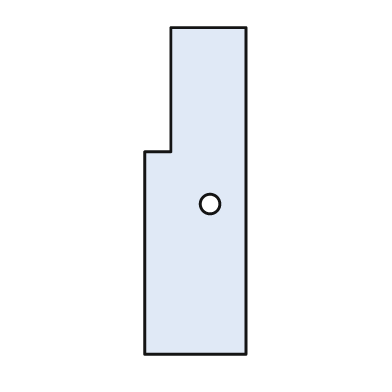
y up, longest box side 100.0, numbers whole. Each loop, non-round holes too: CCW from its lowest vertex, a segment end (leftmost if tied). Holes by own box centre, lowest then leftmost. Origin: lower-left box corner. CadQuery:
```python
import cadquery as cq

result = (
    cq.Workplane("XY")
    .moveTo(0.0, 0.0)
    .lineTo(31.0, 0.0)
    .lineTo(31.0, 100.0)
    .lineTo(8.0, 100.0)
    .lineTo(8.0, 62.0)
    .lineTo(0.0, 62.0)
    .close()
    .moveTo(20.0, 46.0)
    .circle(3.0)
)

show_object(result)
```